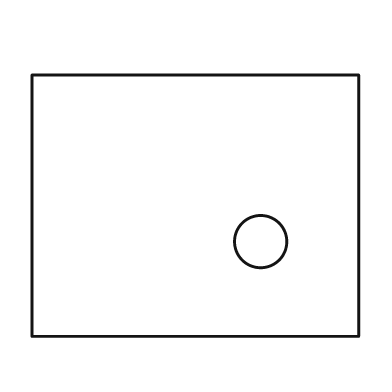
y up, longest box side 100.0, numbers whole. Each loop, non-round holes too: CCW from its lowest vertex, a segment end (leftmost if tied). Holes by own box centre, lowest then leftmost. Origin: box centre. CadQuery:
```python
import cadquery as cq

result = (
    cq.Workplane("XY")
    .moveTo(-50.0, -40.0)
    .lineTo(50.0, -40.0)
    .lineTo(50.0, 40.0)
    .lineTo(-50.0, 40.0)
    .close()
    .moveTo(20.0, -11.0)
    .circle(8.0)
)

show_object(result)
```